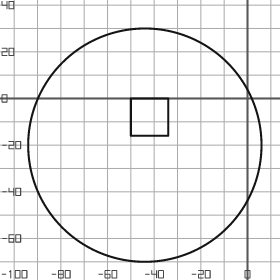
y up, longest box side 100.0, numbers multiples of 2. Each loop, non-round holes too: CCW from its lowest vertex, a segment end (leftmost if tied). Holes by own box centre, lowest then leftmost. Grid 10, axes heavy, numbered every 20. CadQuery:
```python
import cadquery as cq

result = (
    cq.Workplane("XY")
    .moveTo(-44.0, -20.0)
    .circle(50.0)
    .moveTo(-50.0, -16.0)
    .lineTo(-34.0, -16.0)
    .lineTo(-34.0, 0.0)
    .lineTo(-50.0, 0.0)
    .close()
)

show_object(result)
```